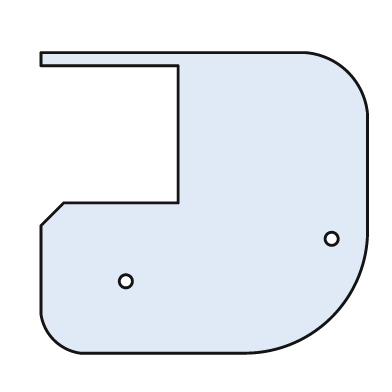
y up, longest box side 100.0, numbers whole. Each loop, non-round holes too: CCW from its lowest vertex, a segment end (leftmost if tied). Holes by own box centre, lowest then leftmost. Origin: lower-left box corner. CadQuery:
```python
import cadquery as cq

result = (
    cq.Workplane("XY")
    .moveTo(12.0, 0.0)
    .lineTo(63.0, 0.0)
    .threePointArc((89.0, 11.0), (100.0, 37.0))
    .lineTo(100.0, 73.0)
    .threePointArc((94.0, 86.0), (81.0, 92.0))
    .lineTo(0.0, 92.0)
    .lineTo(0.0, 88.0)
    .lineTo(42.0, 88.0)
    .lineTo(42.0, 46.0)
    .lineTo(7.0, 46.0)
    .lineTo(0.0, 39.0)
    .lineTo(0.0, 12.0)
    .threePointArc((4.0, 4.0), (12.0, 0.0))
    .close()
    .moveTo(26.0, 22.0)
    .circle(2.0)
    .moveTo(89.0, 35.0)
    .circle(2.0)
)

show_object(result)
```